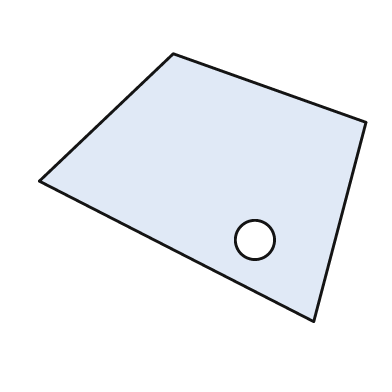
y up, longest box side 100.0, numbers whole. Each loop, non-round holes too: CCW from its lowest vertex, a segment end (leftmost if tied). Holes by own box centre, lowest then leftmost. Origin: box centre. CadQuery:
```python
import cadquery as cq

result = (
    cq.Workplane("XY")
    .moveTo(34.0, -41.0)
    .lineTo(50.0, 20.0)
    .lineTo(-9.0, 41.0)
    .lineTo(-50.0, 2.0)
    .close()
    .moveTo(16.0, -16.0)
    .circle(6.0)
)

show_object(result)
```